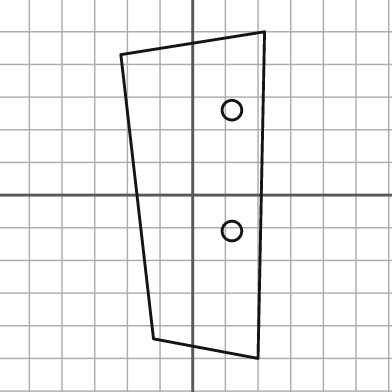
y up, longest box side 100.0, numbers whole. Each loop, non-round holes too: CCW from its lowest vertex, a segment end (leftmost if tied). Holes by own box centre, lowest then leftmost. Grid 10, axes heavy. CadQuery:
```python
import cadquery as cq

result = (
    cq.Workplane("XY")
    .moveTo(20.0, -50.0)
    .lineTo(22.0, 50.0)
    .lineTo(-22.0, 43.0)
    .lineTo(-12.0, -44.0)
    .close()
    .moveTo(12.0, -11.0)
    .circle(3.0)
    .moveTo(12.0, 26.0)
    .circle(3.0)
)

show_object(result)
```